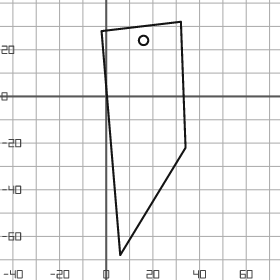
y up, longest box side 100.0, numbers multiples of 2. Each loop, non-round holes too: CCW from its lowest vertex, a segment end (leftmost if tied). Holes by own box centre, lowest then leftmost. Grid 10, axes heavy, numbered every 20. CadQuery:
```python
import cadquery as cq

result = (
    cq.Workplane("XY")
    .moveTo(6.0, -68.0)
    .lineTo(34.0, -22.0)
    .lineTo(32.0, 32.0)
    .lineTo(-2.0, 28.0)
    .close()
    .moveTo(16.0, 24.0)
    .circle(2.0)
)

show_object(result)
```